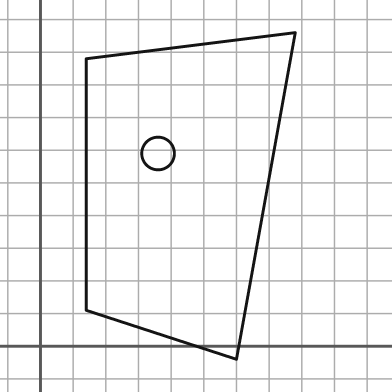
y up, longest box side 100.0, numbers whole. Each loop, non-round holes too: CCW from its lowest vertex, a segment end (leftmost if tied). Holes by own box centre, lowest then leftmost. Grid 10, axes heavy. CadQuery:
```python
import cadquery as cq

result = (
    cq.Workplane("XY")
    .moveTo(60.0, -4.0)
    .lineTo(78.0, 96.0)
    .lineTo(14.0, 88.0)
    .lineTo(14.0, 11.0)
    .close()
    .moveTo(36.0, 59.0)
    .circle(5.0)
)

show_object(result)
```